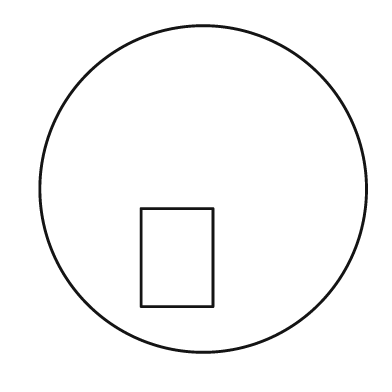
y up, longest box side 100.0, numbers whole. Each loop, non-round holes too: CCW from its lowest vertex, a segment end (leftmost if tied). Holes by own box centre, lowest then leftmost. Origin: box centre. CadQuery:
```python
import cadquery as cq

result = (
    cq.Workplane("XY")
    .moveTo(0.0, 0.0)
    .circle(50.0)
    .moveTo(-19.0, -36.0)
    .lineTo(3.0, -36.0)
    .lineTo(3.0, -6.0)
    .lineTo(-19.0, -6.0)
    .close()
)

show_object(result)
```